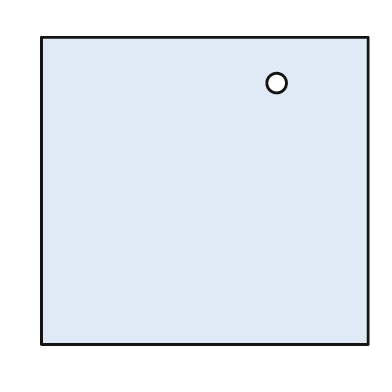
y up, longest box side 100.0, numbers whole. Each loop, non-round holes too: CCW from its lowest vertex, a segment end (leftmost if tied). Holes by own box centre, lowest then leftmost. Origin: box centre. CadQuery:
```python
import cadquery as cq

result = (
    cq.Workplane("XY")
    .moveTo(-50.0, -47.0)
    .lineTo(50.0, -47.0)
    .lineTo(50.0, 47.0)
    .lineTo(-50.0, 47.0)
    .close()
    .moveTo(22.0, 33.0)
    .circle(3.0)
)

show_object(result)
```